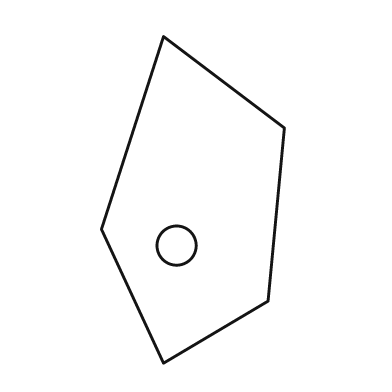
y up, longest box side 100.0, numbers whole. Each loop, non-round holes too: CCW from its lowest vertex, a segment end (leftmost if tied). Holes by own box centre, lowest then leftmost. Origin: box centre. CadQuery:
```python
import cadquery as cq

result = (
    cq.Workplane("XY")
    .moveTo(-9.0, -50.0)
    .lineTo(23.0, -31.0)
    .lineTo(28.0, 22.0)
    .lineTo(-9.0, 50.0)
    .lineTo(-28.0, -9.0)
    .close()
    .moveTo(-5.0, -14.0)
    .circle(6.0)
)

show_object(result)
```